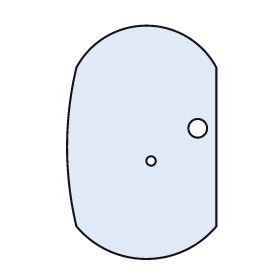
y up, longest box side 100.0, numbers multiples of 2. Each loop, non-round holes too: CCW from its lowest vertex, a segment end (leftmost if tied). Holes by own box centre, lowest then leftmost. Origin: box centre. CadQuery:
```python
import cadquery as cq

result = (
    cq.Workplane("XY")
    .moveTo(-28.0, -36.0)
    .threePointArc((2.0, -50.0), (32.0, -36.0))
    .lineTo(32.0, 32.0)
    .threePointArc((2.0, 50.0), (-28.0, 32.0))
    .threePointArc((-32.0, -2.0), (-28.0, -36.0))
    .close()
    .moveTo(4.0, -8.0)
    .circle(2.0)
    .moveTo(24.0, 6.0)
    .circle(4.0)
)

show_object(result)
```